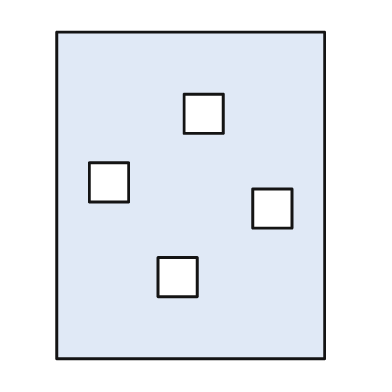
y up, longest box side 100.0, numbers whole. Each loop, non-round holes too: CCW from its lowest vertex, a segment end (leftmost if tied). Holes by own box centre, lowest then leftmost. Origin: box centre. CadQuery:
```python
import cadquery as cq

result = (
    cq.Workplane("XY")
    .moveTo(-41.0, -50.0)
    .lineTo(41.0, -50.0)
    .lineTo(41.0, 50.0)
    .lineTo(-41.0, 50.0)
    .close()
    .moveTo(-10.0, -31.0)
    .lineTo(2.0, -31.0)
    .lineTo(2.0, -19.0)
    .lineTo(-10.0, -19.0)
    .close()
    .moveTo(19.0, -10.0)
    .lineTo(31.0, -10.0)
    .lineTo(31.0, 2.0)
    .lineTo(19.0, 2.0)
    .close()
    .moveTo(-31.0, -2.0)
    .lineTo(-19.0, -2.0)
    .lineTo(-19.0, 10.0)
    .lineTo(-31.0, 10.0)
    .close()
    .moveTo(-2.0, 19.0)
    .lineTo(10.0, 19.0)
    .lineTo(10.0, 31.0)
    .lineTo(-2.0, 31.0)
    .close()
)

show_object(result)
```